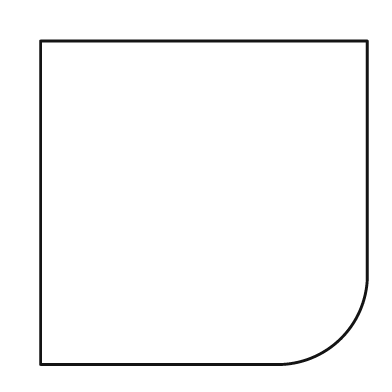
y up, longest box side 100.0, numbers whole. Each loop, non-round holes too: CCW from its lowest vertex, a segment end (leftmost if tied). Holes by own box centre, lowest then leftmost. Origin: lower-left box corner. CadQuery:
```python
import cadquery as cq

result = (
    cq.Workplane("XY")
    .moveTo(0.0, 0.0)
    .lineTo(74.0, 0.0)
    .threePointArc((92.0, 8.0), (100.0, 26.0))
    .lineTo(100.0, 99.0)
    .lineTo(0.0, 99.0)
    .close()
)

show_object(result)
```